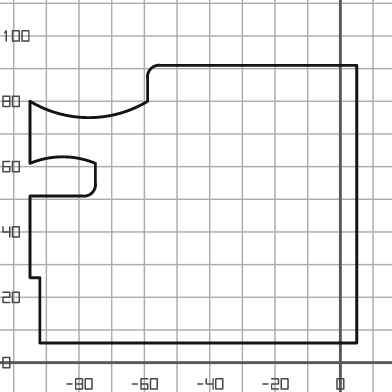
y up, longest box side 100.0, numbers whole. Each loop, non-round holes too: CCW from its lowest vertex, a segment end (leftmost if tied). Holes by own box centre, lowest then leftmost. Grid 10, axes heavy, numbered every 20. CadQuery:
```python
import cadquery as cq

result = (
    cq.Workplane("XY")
    .moveTo(-92.0, 6.0)
    .lineTo(5.0, 6.0)
    .lineTo(5.0, 91.0)
    .lineTo(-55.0, 91.0)
    .threePointArc((-58.0, 90.0), (-59.0, 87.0))
    .lineTo(-59.0, 80.0)
    .threePointArc((-77.0, 75.0), (-95.0, 80.0))
    .lineTo(-95.0, 61.0)
    .threePointArc((-85.0, 63.0), (-75.0, 61.0))
    .lineTo(-75.0, 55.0)
    .threePointArc((-76.0, 52.0), (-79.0, 51.0))
    .lineTo(-95.0, 51.0)
    .lineTo(-95.0, 26.0)
    .lineTo(-92.0, 26.0)
    .close()
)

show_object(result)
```